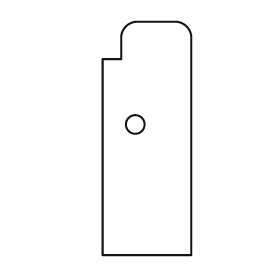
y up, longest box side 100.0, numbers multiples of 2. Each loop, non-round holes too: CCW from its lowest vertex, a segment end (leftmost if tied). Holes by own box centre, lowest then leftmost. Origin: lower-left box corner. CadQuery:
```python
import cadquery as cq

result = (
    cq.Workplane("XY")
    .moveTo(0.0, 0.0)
    .lineTo(38.0, 0.0)
    .lineTo(38.0, 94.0)
    .threePointArc((36.0, 98.0), (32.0, 100.0))
    .lineTo(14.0, 100.0)
    .threePointArc((10.0, 98.0), (8.0, 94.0))
    .lineTo(8.0, 84.0)
    .lineTo(0.0, 84.0)
    .close()
    .moveTo(14.0, 56.0)
    .circle(4.0)
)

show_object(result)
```